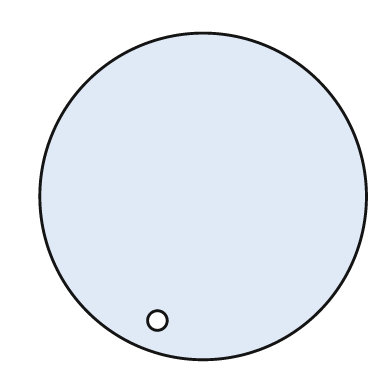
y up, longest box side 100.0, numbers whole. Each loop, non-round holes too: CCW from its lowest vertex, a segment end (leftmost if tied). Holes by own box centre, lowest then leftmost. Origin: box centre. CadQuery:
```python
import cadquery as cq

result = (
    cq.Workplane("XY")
    .moveTo(0.0, 0.0)
    .circle(50.0)
    .moveTo(-14.0, -38.0)
    .circle(3.0)
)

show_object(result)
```